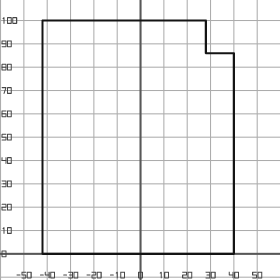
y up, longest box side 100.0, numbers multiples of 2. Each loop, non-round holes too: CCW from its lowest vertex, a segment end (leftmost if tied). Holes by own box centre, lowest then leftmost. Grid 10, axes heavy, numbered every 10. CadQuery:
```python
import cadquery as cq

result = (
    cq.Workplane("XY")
    .moveTo(-42.0, 0.0)
    .lineTo(40.0, 0.0)
    .lineTo(40.0, 86.0)
    .lineTo(28.0, 86.0)
    .lineTo(28.0, 100.0)
    .lineTo(-42.0, 100.0)
    .close()
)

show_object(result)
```